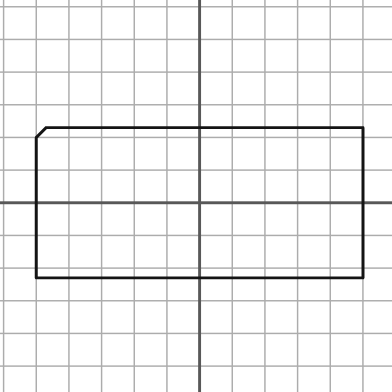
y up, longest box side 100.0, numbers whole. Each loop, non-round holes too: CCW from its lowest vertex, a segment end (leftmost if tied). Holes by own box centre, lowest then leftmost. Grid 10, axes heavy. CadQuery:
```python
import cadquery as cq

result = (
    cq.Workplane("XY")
    .moveTo(-50.0, -23.0)
    .lineTo(50.0, -23.0)
    .lineTo(50.0, 23.0)
    .lineTo(-47.0, 23.0)
    .lineTo(-50.0, 20.0)
    .close()
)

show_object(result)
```